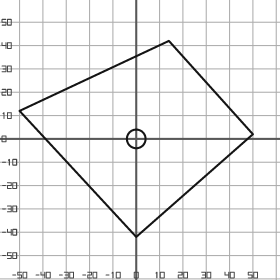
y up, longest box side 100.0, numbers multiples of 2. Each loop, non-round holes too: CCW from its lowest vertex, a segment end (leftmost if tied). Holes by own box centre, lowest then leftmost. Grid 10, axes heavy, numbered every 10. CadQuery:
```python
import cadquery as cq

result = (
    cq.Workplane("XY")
    .moveTo(0.0, -42.0)
    .lineTo(50.0, 2.0)
    .lineTo(14.0, 42.0)
    .lineTo(-50.0, 12.0)
    .close()
    .moveTo(0.0, 0.0)
    .circle(4.0)
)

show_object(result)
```